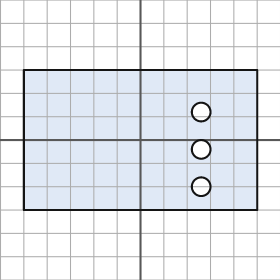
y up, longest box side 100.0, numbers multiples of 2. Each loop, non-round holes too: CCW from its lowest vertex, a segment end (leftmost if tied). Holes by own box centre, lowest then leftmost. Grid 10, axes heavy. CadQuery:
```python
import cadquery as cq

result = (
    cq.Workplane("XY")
    .moveTo(-50.0, -30.0)
    .lineTo(50.0, -30.0)
    .lineTo(50.0, 30.0)
    .lineTo(-50.0, 30.0)
    .close()
    .moveTo(26.0, -20.0)
    .circle(4.0)
    .moveTo(26.0, -4.0)
    .circle(4.0)
    .moveTo(26.0, 12.0)
    .circle(4.0)
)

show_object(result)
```